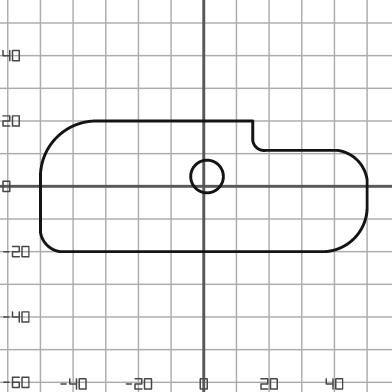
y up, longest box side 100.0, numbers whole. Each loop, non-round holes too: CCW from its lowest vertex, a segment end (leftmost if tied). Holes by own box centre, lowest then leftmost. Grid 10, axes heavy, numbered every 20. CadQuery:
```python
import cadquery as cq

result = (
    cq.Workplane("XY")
    .moveTo(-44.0, -20.0)
    .lineTo(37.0, -20.0)
    .threePointArc((46.0, -16.0), (50.0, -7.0))
    .lineTo(50.0, 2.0)
    .threePointArc((47.0, 8.0), (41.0, 11.0))
    .lineTo(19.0, 11.0)
    .threePointArc((16.0, 12.0), (15.0, 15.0))
    .lineTo(15.0, 20.0)
    .lineTo(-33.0, 20.0)
    .threePointArc((-45.0, 15.0), (-50.0, 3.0))
    .lineTo(-50.0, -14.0)
    .threePointArc((-48.0, -18.0), (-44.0, -20.0))
    .close()
    .moveTo(1.0, 3.0)
    .circle(5.0)
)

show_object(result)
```